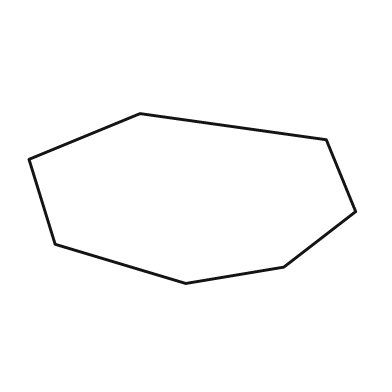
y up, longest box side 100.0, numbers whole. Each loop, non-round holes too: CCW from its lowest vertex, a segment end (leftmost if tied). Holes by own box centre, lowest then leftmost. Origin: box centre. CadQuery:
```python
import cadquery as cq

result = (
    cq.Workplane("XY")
    .moveTo(-2.0, -26.0)
    .lineTo(28.0, -21.0)
    .lineTo(50.0, -4.0)
    .lineTo(41.0, 18.0)
    .lineTo(-16.0, 26.0)
    .lineTo(-50.0, 12.0)
    .lineTo(-42.0, -14.0)
    .close()
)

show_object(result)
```